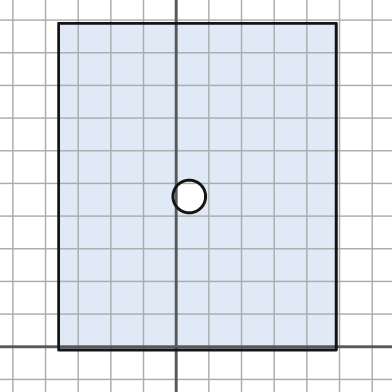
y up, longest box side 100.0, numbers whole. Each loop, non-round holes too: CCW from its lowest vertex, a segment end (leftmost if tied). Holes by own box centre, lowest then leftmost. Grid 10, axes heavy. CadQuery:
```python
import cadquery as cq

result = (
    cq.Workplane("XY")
    .moveTo(-36.0, -1.0)
    .lineTo(49.0, -1.0)
    .lineTo(49.0, 99.0)
    .lineTo(-36.0, 99.0)
    .close()
    .moveTo(4.0, 46.0)
    .circle(5.0)
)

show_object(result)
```